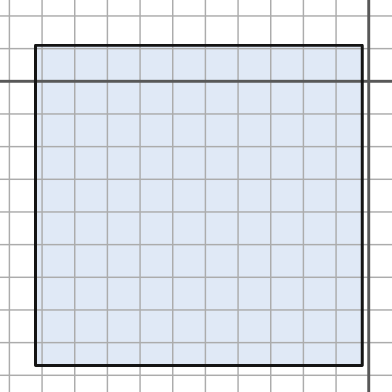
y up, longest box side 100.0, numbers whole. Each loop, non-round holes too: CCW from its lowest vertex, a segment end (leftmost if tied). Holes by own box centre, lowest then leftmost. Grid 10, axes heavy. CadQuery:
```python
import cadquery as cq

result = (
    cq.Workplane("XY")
    .moveTo(-102.0, -87.0)
    .lineTo(-2.0, -87.0)
    .lineTo(-2.0, 11.0)
    .lineTo(-102.0, 11.0)
    .close()
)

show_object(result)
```